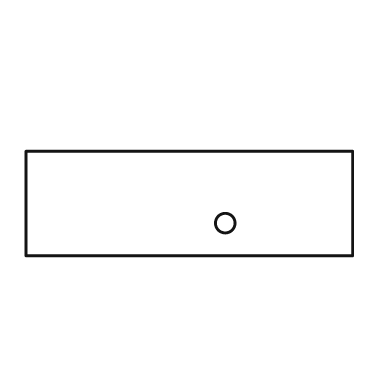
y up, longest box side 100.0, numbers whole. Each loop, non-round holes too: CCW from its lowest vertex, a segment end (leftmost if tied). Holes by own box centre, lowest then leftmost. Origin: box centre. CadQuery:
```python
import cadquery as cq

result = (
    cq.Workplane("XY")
    .moveTo(-50.0, -16.0)
    .lineTo(50.0, -16.0)
    .lineTo(50.0, 16.0)
    .lineTo(-50.0, 16.0)
    .close()
    .moveTo(11.0, -6.0)
    .circle(3.0)
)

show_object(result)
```